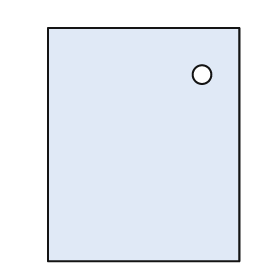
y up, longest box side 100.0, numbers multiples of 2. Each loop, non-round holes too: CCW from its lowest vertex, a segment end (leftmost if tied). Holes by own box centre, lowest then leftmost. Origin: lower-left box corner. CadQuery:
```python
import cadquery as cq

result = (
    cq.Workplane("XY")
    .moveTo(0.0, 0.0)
    .lineTo(82.0, 0.0)
    .lineTo(82.0, 100.0)
    .lineTo(0.0, 100.0)
    .close()
    .moveTo(66.0, 80.0)
    .circle(4.0)
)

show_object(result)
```